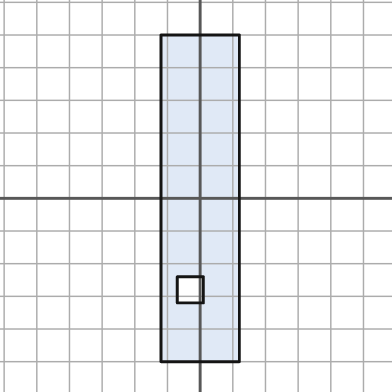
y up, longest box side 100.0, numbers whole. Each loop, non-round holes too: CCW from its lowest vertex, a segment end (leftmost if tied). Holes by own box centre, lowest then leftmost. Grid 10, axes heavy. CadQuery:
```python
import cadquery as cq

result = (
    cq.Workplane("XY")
    .moveTo(-12.0, -50.0)
    .lineTo(12.0, -50.0)
    .lineTo(12.0, 50.0)
    .lineTo(-12.0, 50.0)
    .close()
    .moveTo(-7.0, -32.0)
    .lineTo(1.0, -32.0)
    .lineTo(1.0, -24.0)
    .lineTo(-7.0, -24.0)
    .close()
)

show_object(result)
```